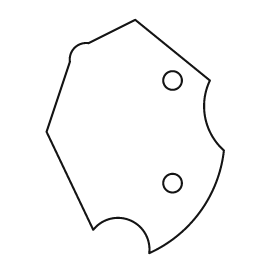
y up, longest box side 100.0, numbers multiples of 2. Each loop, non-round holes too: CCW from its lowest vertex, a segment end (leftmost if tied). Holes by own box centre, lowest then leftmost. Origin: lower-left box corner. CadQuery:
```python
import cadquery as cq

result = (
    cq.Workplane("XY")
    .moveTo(44.0, 0.0)
    .threePointArc((66.0, 18.0), (76.0, 44.0))
    .threePointArc((68.0, 58.0), (70.0, 74.0))
    .lineTo(38.0, 100.0)
    .lineTo(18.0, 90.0)
    .threePointArc((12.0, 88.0), (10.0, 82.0))
    .lineTo(0.0, 52.0)
    .lineTo(20.0, 10.0)
    .threePointArc((36.0, 14.0), (44.0, 0.0))
    .close()
    .moveTo(54.0, 30.0)
    .circle(4.0)
    .moveTo(54.0, 74.0)
    .circle(4.0)
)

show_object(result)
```